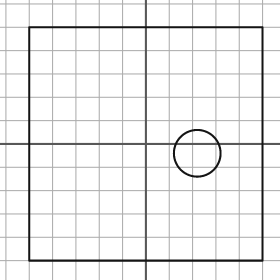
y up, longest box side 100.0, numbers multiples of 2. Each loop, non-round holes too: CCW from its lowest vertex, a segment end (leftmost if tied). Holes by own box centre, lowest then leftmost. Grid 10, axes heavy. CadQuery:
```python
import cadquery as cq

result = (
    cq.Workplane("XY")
    .moveTo(-50.0, -50.0)
    .lineTo(50.0, -50.0)
    .lineTo(50.0, 50.0)
    .lineTo(-50.0, 50.0)
    .close()
    .moveTo(22.0, -4.0)
    .circle(10.0)
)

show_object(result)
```